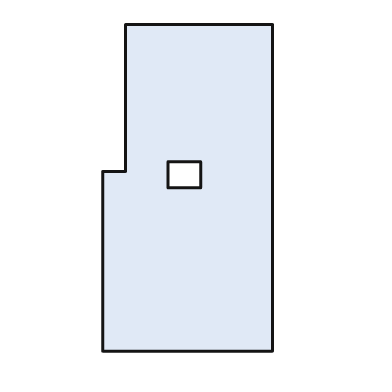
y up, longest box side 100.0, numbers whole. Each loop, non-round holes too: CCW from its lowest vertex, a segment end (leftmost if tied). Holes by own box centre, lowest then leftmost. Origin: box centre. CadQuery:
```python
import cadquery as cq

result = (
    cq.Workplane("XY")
    .moveTo(-26.0, -50.0)
    .lineTo(26.0, -50.0)
    .lineTo(26.0, 50.0)
    .lineTo(-19.0, 50.0)
    .lineTo(-19.0, 5.0)
    .lineTo(-26.0, 5.0)
    .close()
    .moveTo(-6.0, 0.0)
    .lineTo(4.0, 0.0)
    .lineTo(4.0, 8.0)
    .lineTo(-6.0, 8.0)
    .close()
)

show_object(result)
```